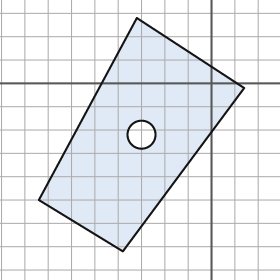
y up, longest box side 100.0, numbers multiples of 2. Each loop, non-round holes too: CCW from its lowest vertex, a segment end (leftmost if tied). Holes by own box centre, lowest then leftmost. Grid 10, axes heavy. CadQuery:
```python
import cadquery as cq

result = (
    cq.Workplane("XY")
    .moveTo(-38.0, -72.0)
    .lineTo(14.0, -2.0)
    .lineTo(-32.0, 28.0)
    .lineTo(-74.0, -50.0)
    .close()
    .moveTo(-30.0, -22.0)
    .circle(6.0)
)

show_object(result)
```